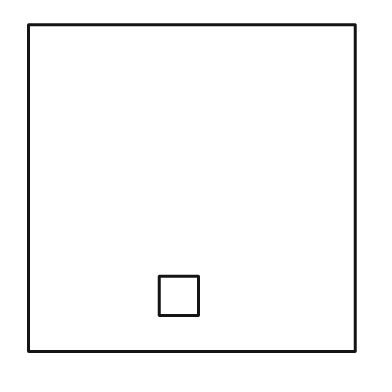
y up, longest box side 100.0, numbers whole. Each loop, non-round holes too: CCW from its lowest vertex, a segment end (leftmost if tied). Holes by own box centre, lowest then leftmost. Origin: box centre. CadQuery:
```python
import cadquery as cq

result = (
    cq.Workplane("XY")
    .moveTo(-50.0, -50.0)
    .lineTo(50.0, -50.0)
    .lineTo(50.0, 50.0)
    .lineTo(-50.0, 50.0)
    .close()
    .moveTo(-10.0, -39.0)
    .lineTo(2.0, -39.0)
    .lineTo(2.0, -27.0)
    .lineTo(-10.0, -27.0)
    .close()
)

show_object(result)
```